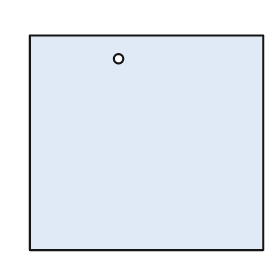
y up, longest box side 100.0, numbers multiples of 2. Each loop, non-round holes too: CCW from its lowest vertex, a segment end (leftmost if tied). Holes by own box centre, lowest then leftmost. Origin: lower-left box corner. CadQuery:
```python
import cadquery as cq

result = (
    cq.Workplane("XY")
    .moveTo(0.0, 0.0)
    .lineTo(100.0, 0.0)
    .lineTo(100.0, 92.0)
    .lineTo(0.0, 92.0)
    .close()
    .moveTo(38.0, 82.0)
    .circle(2.0)
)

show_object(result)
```